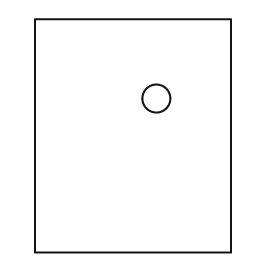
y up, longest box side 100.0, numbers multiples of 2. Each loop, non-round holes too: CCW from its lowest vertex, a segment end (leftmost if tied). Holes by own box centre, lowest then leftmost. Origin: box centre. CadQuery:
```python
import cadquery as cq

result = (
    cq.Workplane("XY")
    .moveTo(-42.0, -50.0)
    .lineTo(42.0, -50.0)
    .lineTo(42.0, 50.0)
    .lineTo(-42.0, 50.0)
    .close()
    .moveTo(10.0, 16.0)
    .circle(6.0)
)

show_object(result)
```